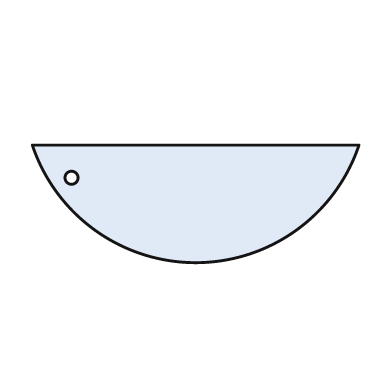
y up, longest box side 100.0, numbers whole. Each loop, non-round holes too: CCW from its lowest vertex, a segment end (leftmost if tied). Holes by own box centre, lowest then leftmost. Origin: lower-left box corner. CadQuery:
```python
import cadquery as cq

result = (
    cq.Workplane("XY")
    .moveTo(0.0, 36.0)
    .threePointArc((50.0, 0.0), (100.0, 36.0))
    .close()
    .moveTo(12.0, 26.0)
    .circle(2.0)
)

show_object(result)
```